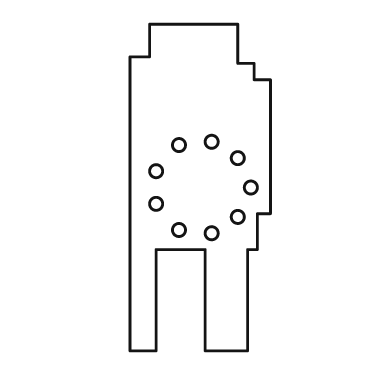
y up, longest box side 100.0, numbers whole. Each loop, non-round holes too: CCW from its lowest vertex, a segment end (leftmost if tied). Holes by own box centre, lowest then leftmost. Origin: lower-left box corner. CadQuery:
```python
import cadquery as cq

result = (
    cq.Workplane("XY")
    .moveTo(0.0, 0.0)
    .lineTo(8.0, 0.0)
    .lineTo(8.0, 31.0)
    .lineTo(23.0, 31.0)
    .lineTo(23.0, 0.0)
    .lineTo(36.0, 0.0)
    .lineTo(36.0, 31.0)
    .lineTo(39.0, 31.0)
    .lineTo(39.0, 42.0)
    .lineTo(43.0, 42.0)
    .lineTo(43.0, 83.0)
    .lineTo(38.0, 83.0)
    .lineTo(38.0, 88.0)
    .lineTo(33.0, 88.0)
    .lineTo(33.0, 100.0)
    .lineTo(6.0, 100.0)
    .lineTo(6.0, 90.0)
    .lineTo(0.0, 90.0)
    .close()
    .moveTo(25.0, 36.0)
    .circle(2.0)
    .moveTo(15.0, 37.0)
    .circle(2.0)
    .moveTo(33.0, 41.0)
    .circle(2.0)
    .moveTo(8.0, 45.0)
    .circle(2.0)
    .moveTo(37.0, 50.0)
    .circle(2.0)
    .moveTo(8.0, 55.0)
    .circle(2.0)
    .moveTo(33.0, 59.0)
    .circle(2.0)
    .moveTo(15.0, 63.0)
    .circle(2.0)
    .moveTo(25.0, 64.0)
    .circle(2.0)
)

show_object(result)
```